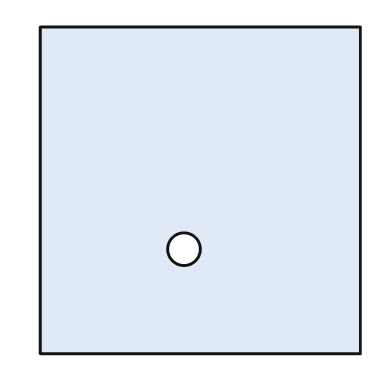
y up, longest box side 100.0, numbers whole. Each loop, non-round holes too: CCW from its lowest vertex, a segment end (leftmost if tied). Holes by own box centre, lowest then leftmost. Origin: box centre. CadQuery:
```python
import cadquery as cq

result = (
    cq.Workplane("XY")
    .moveTo(-49.0, -50.0)
    .lineTo(49.0, -50.0)
    .lineTo(49.0, 50.0)
    .lineTo(-49.0, 50.0)
    .close()
    .moveTo(-5.0, -18.0)
    .circle(5.0)
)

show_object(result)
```